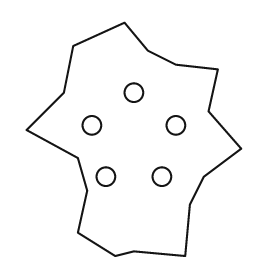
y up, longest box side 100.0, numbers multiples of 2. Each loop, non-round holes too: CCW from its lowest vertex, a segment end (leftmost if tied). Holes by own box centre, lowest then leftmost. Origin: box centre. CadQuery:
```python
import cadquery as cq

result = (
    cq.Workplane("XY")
    .moveTo(-8.0, -50.0)
    .lineTo(0.0, -48.0)
    .lineTo(22.0, -50.0)
    .lineTo(24.0, -28.0)
    .lineTo(30.0, -16.0)
    .lineTo(46.0, -4.0)
    .lineTo(32.0, 12.0)
    .lineTo(36.0, 30.0)
    .lineTo(18.0, 32.0)
    .lineTo(6.0, 38.0)
    .lineTo(-4.0, 50.0)
    .lineTo(-26.0, 40.0)
    .lineTo(-30.0, 20.0)
    .lineTo(-46.0, 4.0)
    .lineTo(-24.0, -8.0)
    .lineTo(-20.0, -22.0)
    .lineTo(-24.0, -40.0)
    .close()
    .moveTo(-12.0, -16.0)
    .circle(4.0)
    .moveTo(12.0, -16.0)
    .circle(4.0)
    .moveTo(-18.0, 6.0)
    .circle(4.0)
    .moveTo(18.0, 6.0)
    .circle(4.0)
    .moveTo(0.0, 20.0)
    .circle(4.0)
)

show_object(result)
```